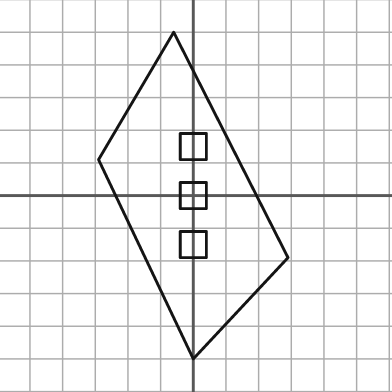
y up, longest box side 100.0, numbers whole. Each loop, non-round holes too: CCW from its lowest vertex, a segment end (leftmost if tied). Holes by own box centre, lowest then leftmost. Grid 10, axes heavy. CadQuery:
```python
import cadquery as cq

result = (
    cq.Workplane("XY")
    .moveTo(0.0, -50.0)
    .lineTo(29.0, -19.0)
    .lineTo(-6.0, 50.0)
    .lineTo(-29.0, 11.0)
    .close()
    .moveTo(-4.0, -19.0)
    .lineTo(4.0, -19.0)
    .lineTo(4.0, -11.0)
    .lineTo(-4.0, -11.0)
    .close()
    .moveTo(-4.0, -4.0)
    .lineTo(4.0, -4.0)
    .lineTo(4.0, 4.0)
    .lineTo(-4.0, 4.0)
    .close()
    .moveTo(-4.0, 11.0)
    .lineTo(4.0, 11.0)
    .lineTo(4.0, 19.0)
    .lineTo(-4.0, 19.0)
    .close()
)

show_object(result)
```